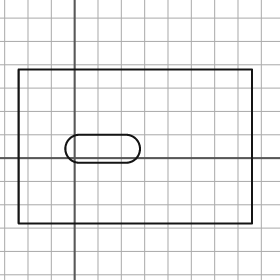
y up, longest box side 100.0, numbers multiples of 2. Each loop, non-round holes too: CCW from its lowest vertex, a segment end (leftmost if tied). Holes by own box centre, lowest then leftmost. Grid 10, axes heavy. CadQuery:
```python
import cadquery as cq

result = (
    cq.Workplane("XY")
    .moveTo(-24.0, -28.0)
    .lineTo(76.0, -28.0)
    .lineTo(76.0, 38.0)
    .lineTo(-24.0, 38.0)
    .close()
    .moveTo(2.0, -2.0)
    .lineTo(22.0, -2.0)
    .threePointArc((28.0, 4.0), (22.0, 10.0))
    .lineTo(2.0, 10.0)
    .threePointArc((-4.0, 4.0), (2.0, -2.0))
    .close()
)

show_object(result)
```